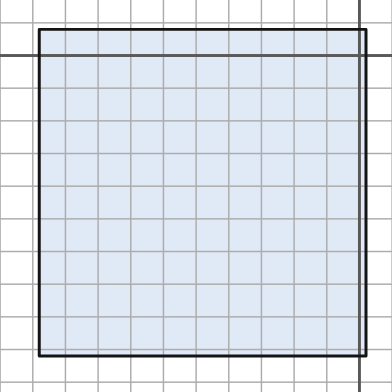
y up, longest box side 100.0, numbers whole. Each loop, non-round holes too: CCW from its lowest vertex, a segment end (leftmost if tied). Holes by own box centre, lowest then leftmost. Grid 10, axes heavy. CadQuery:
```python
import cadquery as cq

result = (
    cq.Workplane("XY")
    .moveTo(-98.0, -92.0)
    .lineTo(2.0, -92.0)
    .lineTo(2.0, 8.0)
    .lineTo(-98.0, 8.0)
    .close()
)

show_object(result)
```